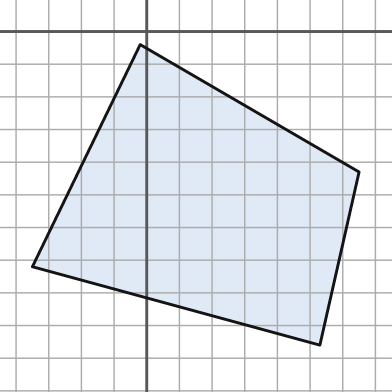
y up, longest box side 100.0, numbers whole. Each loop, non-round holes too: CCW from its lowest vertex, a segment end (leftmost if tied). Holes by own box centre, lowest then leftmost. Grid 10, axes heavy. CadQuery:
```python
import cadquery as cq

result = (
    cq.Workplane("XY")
    .moveTo(53.0, -96.0)
    .lineTo(65.0, -43.0)
    .lineTo(-2.0, -4.0)
    .lineTo(-35.0, -72.0)
    .close()
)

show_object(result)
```